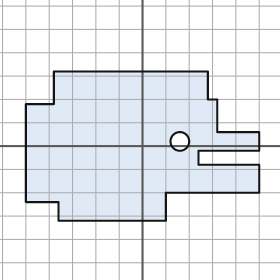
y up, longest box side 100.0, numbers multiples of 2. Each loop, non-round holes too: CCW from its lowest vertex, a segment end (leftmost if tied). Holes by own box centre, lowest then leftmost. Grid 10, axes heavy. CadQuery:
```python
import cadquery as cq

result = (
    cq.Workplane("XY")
    .moveTo(-36.0, -32.0)
    .lineTo(10.0, -32.0)
    .lineTo(10.0, -20.0)
    .lineTo(50.0, -20.0)
    .lineTo(50.0, -8.0)
    .lineTo(24.0, -8.0)
    .lineTo(24.0, -2.0)
    .lineTo(50.0, -2.0)
    .lineTo(50.0, 6.0)
    .lineTo(32.0, 6.0)
    .lineTo(32.0, 20.0)
    .lineTo(28.0, 20.0)
    .lineTo(28.0, 32.0)
    .lineTo(-38.0, 32.0)
    .lineTo(-38.0, 18.0)
    .lineTo(-50.0, 18.0)
    .lineTo(-50.0, -24.0)
    .lineTo(-36.0, -24.0)
    .close()
    .moveTo(16.0, 2.0)
    .circle(4.0)
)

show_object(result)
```